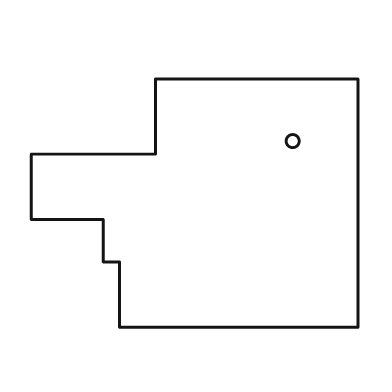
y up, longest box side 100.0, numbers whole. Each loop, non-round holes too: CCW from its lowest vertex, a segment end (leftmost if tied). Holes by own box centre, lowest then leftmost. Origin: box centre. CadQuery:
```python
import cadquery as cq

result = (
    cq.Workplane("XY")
    .moveTo(-23.0, -38.0)
    .lineTo(50.0, -38.0)
    .lineTo(50.0, 38.0)
    .lineTo(-12.0, 38.0)
    .lineTo(-12.0, 15.0)
    .lineTo(-50.0, 15.0)
    .lineTo(-50.0, -5.0)
    .lineTo(-28.0, -5.0)
    .lineTo(-28.0, -18.0)
    .lineTo(-23.0, -18.0)
    .close()
    .moveTo(30.0, 19.0)
    .circle(2.0)
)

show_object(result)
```